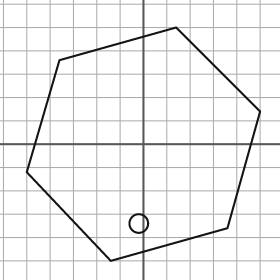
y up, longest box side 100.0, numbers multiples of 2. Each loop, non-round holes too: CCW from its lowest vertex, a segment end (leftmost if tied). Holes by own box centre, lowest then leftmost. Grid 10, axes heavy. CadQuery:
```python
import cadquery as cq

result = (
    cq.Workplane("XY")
    .moveTo(-14.0, -50.0)
    .lineTo(36.0, -36.0)
    .lineTo(50.0, 14.0)
    .lineTo(14.0, 50.0)
    .lineTo(-36.0, 36.0)
    .lineTo(-50.0, -12.0)
    .close()
    .moveTo(-2.0, -34.0)
    .circle(4.0)
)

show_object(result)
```